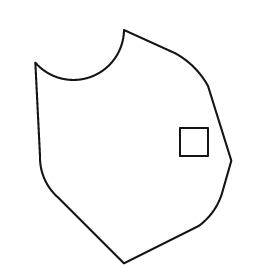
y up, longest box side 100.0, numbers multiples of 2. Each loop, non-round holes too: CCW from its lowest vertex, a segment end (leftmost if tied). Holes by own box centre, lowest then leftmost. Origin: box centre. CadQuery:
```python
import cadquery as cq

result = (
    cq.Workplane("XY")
    .moveTo(-4.0, -50.0)
    .lineTo(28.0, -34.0)
    .threePointArc((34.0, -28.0), (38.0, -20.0))
    .lineTo(42.0, -6.0)
    .lineTo(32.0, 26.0)
    .threePointArc((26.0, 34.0), (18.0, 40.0))
    .lineTo(-4.0, 50.0)
    .threePointArc((-18.0, 30.0), (-42.0, 36.0))
    .lineTo(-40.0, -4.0)
    .threePointArc((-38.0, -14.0), (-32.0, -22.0))
    .close()
    .moveTo(20.0, -4.0)
    .lineTo(32.0, -4.0)
    .lineTo(32.0, 8.0)
    .lineTo(20.0, 8.0)
    .close()
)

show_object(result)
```